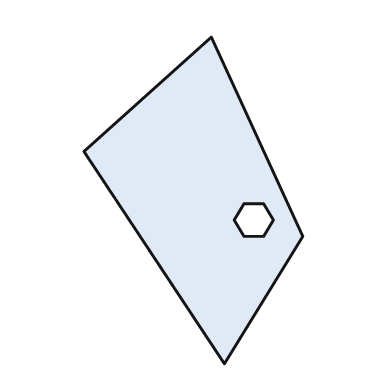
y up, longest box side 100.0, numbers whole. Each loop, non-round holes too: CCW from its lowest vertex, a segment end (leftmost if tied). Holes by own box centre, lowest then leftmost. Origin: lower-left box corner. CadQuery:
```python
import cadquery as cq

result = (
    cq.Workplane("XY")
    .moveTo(43.0, 0.0)
    .lineTo(67.0, 39.0)
    .lineTo(39.0, 100.0)
    .lineTo(0.0, 65.0)
    .close()
    .moveTo(49.0, 39.0)
    .lineTo(55.0, 39.0)
    .lineTo(58.0, 44.0)
    .lineTo(55.0, 49.0)
    .lineTo(49.0, 49.0)
    .lineTo(46.0, 44.0)
    .close()
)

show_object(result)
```